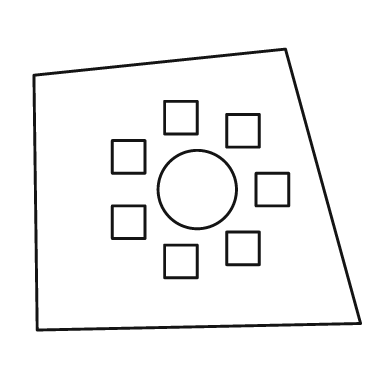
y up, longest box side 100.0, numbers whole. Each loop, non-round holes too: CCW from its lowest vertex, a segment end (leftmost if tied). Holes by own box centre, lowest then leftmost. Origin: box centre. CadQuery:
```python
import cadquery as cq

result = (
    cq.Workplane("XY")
    .moveTo(-49.0, -43.0)
    .lineTo(50.0, -41.0)
    .lineTo(27.0, 43.0)
    .lineTo(-50.0, 35.0)
    .close()
    .moveTo(-10.0, -27.0)
    .lineTo(0.0, -27.0)
    .lineTo(0.0, -17.0)
    .lineTo(-10.0, -17.0)
    .close()
    .moveTo(9.0, -23.0)
    .lineTo(19.0, -23.0)
    .lineTo(19.0, -13.0)
    .lineTo(9.0, -13.0)
    .close()
    .moveTo(-26.0, -15.0)
    .lineTo(-16.0, -15.0)
    .lineTo(-16.0, -5.0)
    .lineTo(-26.0, -5.0)
    .close()
    .moveTo(0.0, 0.0)
    .circle(12.0)
    .moveTo(18.0, -5.0)
    .lineTo(28.0, -5.0)
    .lineTo(28.0, 5.0)
    .lineTo(18.0, 5.0)
    .close()
    .moveTo(-26.0, 5.0)
    .lineTo(-16.0, 5.0)
    .lineTo(-16.0, 15.0)
    .lineTo(-26.0, 15.0)
    .close()
    .moveTo(9.0, 13.0)
    .lineTo(19.0, 13.0)
    .lineTo(19.0, 23.0)
    .lineTo(9.0, 23.0)
    .close()
    .moveTo(-10.0, 17.0)
    .lineTo(0.0, 17.0)
    .lineTo(0.0, 27.0)
    .lineTo(-10.0, 27.0)
    .close()
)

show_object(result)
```